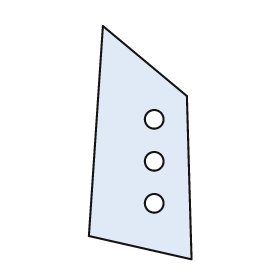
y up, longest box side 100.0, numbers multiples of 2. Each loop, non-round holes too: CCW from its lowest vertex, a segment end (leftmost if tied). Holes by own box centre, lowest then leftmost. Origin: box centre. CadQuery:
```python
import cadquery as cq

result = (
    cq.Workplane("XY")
    .moveTo(22.0, -50.0)
    .lineTo(20.0, 20.0)
    .lineTo(-16.0, 50.0)
    .lineTo(-22.0, -40.0)
    .close()
    .moveTo(6.0, -26.0)
    .circle(4.0)
    .moveTo(6.0, -8.0)
    .circle(4.0)
    .moveTo(6.0, 10.0)
    .circle(4.0)
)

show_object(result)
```